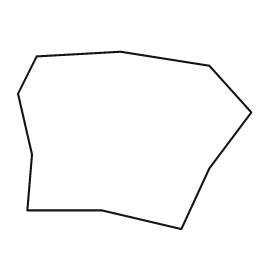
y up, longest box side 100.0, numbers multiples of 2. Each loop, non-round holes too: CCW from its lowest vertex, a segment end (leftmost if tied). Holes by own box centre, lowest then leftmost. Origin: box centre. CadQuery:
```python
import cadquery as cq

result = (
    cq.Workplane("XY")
    .moveTo(20.0, -38.0)
    .lineTo(32.0, -12.0)
    .lineTo(50.0, 12.0)
    .lineTo(32.0, 32.0)
    .lineTo(-6.0, 38.0)
    .lineTo(-42.0, 36.0)
    .lineTo(-50.0, 20.0)
    .lineTo(-44.0, -6.0)
    .lineTo(-46.0, -30.0)
    .lineTo(-14.0, -30.0)
    .close()
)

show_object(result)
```